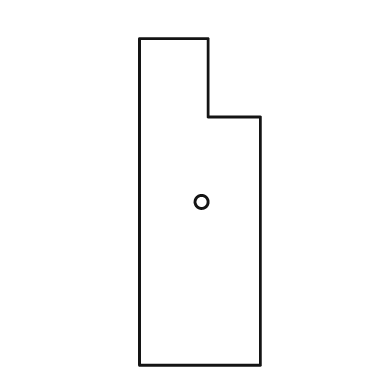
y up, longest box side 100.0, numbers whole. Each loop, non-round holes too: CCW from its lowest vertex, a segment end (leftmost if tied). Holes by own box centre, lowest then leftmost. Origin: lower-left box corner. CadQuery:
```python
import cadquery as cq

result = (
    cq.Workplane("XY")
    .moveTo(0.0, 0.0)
    .lineTo(37.0, 0.0)
    .lineTo(37.0, 76.0)
    .lineTo(21.0, 76.0)
    .lineTo(21.0, 100.0)
    .lineTo(0.0, 100.0)
    .close()
    .moveTo(19.0, 50.0)
    .circle(2.0)
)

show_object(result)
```